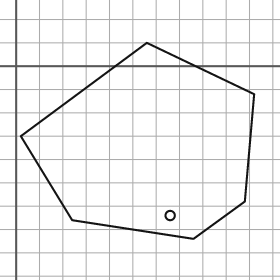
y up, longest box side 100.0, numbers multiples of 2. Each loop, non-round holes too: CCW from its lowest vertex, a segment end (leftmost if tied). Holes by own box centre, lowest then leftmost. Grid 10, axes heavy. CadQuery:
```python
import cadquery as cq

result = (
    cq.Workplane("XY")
    .moveTo(76.0, -74.0)
    .lineTo(98.0, -58.0)
    .lineTo(102.0, -12.0)
    .lineTo(56.0, 10.0)
    .lineTo(2.0, -30.0)
    .lineTo(24.0, -66.0)
    .close()
    .moveTo(66.0, -64.0)
    .circle(2.0)
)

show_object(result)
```